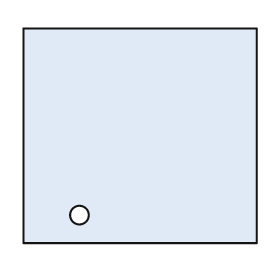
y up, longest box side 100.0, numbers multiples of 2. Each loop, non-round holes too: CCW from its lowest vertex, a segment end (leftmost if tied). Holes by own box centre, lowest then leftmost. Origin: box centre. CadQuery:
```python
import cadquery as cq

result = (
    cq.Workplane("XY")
    .moveTo(-50.0, -46.0)
    .lineTo(50.0, -46.0)
    .lineTo(50.0, 46.0)
    .lineTo(-50.0, 46.0)
    .close()
    .moveTo(-26.0, -34.0)
    .circle(4.0)
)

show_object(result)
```